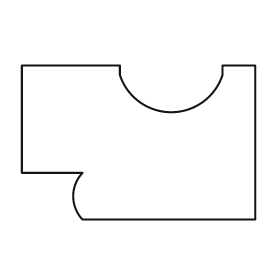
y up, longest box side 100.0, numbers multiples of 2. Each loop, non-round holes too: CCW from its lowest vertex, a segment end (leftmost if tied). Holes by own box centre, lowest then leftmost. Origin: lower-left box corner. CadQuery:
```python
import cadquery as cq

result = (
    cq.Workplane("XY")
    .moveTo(26.0, 0.0)
    .lineTo(100.0, 0.0)
    .lineTo(100.0, 66.0)
    .lineTo(86.0, 66.0)
    .lineTo(86.0, 62.0)
    .threePointArc((64.0, 46.0), (42.0, 62.0))
    .lineTo(42.0, 66.0)
    .lineTo(0.0, 66.0)
    .lineTo(0.0, 20.0)
    .lineTo(26.0, 20.0)
    .threePointArc((22.0, 10.0), (26.0, 0.0))
    .close()
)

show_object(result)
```